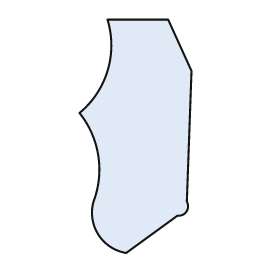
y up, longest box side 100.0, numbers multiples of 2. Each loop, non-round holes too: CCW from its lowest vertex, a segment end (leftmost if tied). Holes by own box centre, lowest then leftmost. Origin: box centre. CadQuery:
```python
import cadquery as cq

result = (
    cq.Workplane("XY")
    .moveTo(-4.0, -50.0)
    .lineTo(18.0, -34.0)
    .threePointArc((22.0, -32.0), (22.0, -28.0))
    .lineTo(24.0, 28.0)
    .lineTo(14.0, 50.0)
    .lineTo(-12.0, 50.0)
    .threePointArc((-12.0, 28.0), (-24.0, 10.0))
    .threePointArc((-16.0, -8.0), (-18.0, -28.0))
    .threePointArc((-16.0, -42.0), (-4.0, -50.0))
    .close()
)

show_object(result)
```